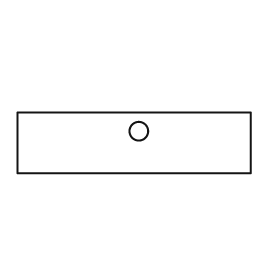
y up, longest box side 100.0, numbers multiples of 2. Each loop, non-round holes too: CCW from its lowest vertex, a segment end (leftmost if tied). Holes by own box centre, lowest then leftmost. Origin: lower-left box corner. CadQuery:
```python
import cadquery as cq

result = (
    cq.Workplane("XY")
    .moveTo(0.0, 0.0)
    .lineTo(100.0, 0.0)
    .lineTo(100.0, 26.0)
    .lineTo(0.0, 26.0)
    .close()
    .moveTo(52.0, 18.0)
    .circle(4.0)
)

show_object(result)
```